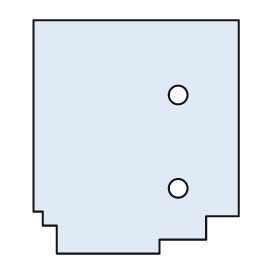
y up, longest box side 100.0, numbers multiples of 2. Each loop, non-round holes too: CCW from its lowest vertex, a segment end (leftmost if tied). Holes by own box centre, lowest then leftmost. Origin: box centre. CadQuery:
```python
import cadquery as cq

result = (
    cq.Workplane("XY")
    .moveTo(-34.0, -50.0)
    .lineTo(10.0, -50.0)
    .lineTo(10.0, -44.0)
    .lineTo(30.0, -44.0)
    .lineTo(30.0, -34.0)
    .lineTo(44.0, -34.0)
    .lineTo(44.0, 50.0)
    .lineTo(-44.0, 50.0)
    .lineTo(-44.0, -32.0)
    .lineTo(-40.0, -32.0)
    .lineTo(-40.0, -38.0)
    .lineTo(-34.0, -38.0)
    .close()
    .moveTo(18.0, -22.0)
    .circle(4.0)
    .moveTo(18.0, 18.0)
    .circle(4.0)
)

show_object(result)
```